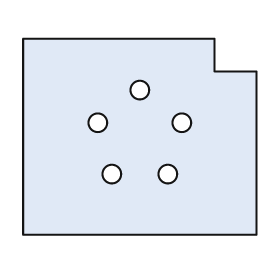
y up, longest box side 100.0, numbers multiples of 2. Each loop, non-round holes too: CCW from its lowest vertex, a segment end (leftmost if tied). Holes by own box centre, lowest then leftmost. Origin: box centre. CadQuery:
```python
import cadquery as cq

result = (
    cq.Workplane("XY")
    .moveTo(-50.0, -42.0)
    .lineTo(50.0, -42.0)
    .lineTo(50.0, 28.0)
    .lineTo(32.0, 28.0)
    .lineTo(32.0, 42.0)
    .lineTo(-50.0, 42.0)
    .close()
    .moveTo(-12.0, -16.0)
    .circle(4.0)
    .moveTo(12.0, -16.0)
    .circle(4.0)
    .moveTo(-18.0, 6.0)
    .circle(4.0)
    .moveTo(18.0, 6.0)
    .circle(4.0)
    .moveTo(0.0, 20.0)
    .circle(4.0)
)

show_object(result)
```